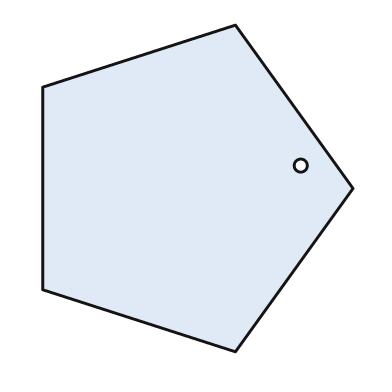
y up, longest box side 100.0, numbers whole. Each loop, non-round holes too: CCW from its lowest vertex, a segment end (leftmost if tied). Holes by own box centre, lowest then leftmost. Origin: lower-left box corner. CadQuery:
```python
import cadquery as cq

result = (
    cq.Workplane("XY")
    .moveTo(59.0, 0.0)
    .lineTo(95.0, 50.0)
    .lineTo(59.0, 100.0)
    .lineTo(0.0, 81.0)
    .lineTo(0.0, 19.0)
    .close()
    .moveTo(79.0, 57.0)
    .circle(2.0)
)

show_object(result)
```